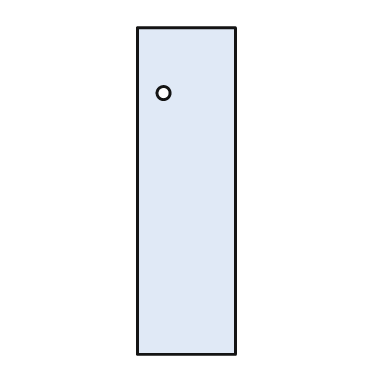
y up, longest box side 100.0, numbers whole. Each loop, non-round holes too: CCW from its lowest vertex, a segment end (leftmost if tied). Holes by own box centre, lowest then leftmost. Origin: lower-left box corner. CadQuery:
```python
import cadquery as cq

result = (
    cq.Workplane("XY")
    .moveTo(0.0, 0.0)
    .lineTo(30.0, 0.0)
    .lineTo(30.0, 100.0)
    .lineTo(0.0, 100.0)
    .close()
    .moveTo(8.0, 80.0)
    .circle(2.0)
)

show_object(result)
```